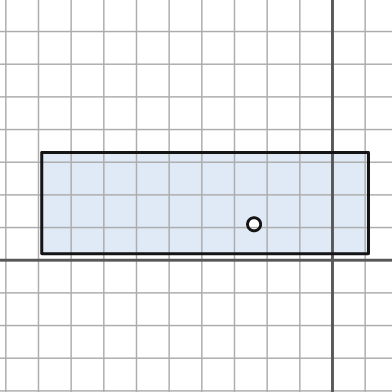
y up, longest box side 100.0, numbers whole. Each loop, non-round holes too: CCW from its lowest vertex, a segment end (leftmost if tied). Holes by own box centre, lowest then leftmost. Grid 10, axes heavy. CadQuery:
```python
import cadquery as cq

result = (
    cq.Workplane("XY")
    .moveTo(-89.0, 2.0)
    .lineTo(11.0, 2.0)
    .lineTo(11.0, 33.0)
    .lineTo(-89.0, 33.0)
    .close()
    .moveTo(-24.0, 11.0)
    .circle(2.0)
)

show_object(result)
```